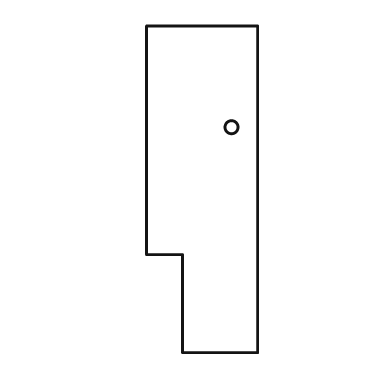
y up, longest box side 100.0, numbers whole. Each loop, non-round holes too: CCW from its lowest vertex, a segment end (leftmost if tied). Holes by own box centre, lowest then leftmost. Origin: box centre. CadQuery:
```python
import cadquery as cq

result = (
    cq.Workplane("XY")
    .moveTo(-6.0, -50.0)
    .lineTo(17.0, -50.0)
    .lineTo(17.0, 50.0)
    .lineTo(-17.0, 50.0)
    .lineTo(-17.0, -20.0)
    .lineTo(-6.0, -20.0)
    .close()
    .moveTo(9.0, 19.0)
    .circle(2.0)
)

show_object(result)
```